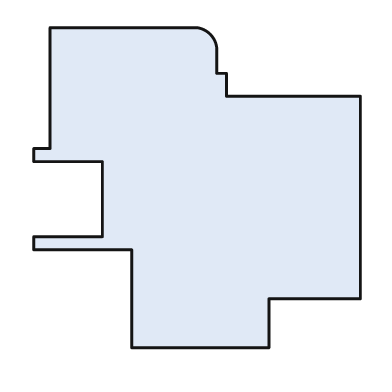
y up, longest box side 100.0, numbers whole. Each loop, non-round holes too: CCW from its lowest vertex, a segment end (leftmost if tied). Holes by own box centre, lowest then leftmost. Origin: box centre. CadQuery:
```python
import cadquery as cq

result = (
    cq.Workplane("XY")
    .moveTo(-20.0, -49.0)
    .lineTo(22.0, -49.0)
    .lineTo(22.0, -34.0)
    .lineTo(50.0, -34.0)
    .lineTo(50.0, 28.0)
    .lineTo(9.0, 28.0)
    .lineTo(9.0, 35.0)
    .lineTo(6.0, 35.0)
    .lineTo(6.0, 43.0)
    .threePointArc((4.0, 47.0), (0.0, 49.0))
    .lineTo(-45.0, 49.0)
    .lineTo(-45.0, 12.0)
    .lineTo(-50.0, 12.0)
    .lineTo(-50.0, 8.0)
    .lineTo(-29.0, 8.0)
    .lineTo(-29.0, -15.0)
    .lineTo(-50.0, -15.0)
    .lineTo(-50.0, -19.0)
    .lineTo(-20.0, -19.0)
    .close()
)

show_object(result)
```